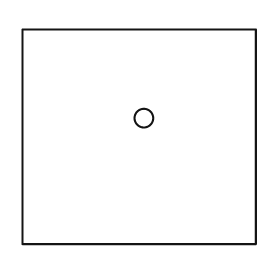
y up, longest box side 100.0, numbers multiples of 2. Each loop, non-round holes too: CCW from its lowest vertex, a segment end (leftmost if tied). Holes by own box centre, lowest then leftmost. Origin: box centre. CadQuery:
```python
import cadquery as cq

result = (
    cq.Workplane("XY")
    .moveTo(-50.0, -46.0)
    .lineTo(50.0, -46.0)
    .lineTo(50.0, 46.0)
    .lineTo(-50.0, 46.0)
    .close()
    .moveTo(2.0, 8.0)
    .circle(4.0)
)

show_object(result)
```